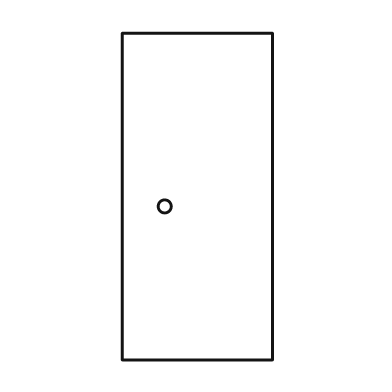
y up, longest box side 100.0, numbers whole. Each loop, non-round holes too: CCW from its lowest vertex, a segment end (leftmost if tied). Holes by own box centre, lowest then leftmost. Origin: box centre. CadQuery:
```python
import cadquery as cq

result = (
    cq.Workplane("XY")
    .moveTo(-23.0, -50.0)
    .lineTo(23.0, -50.0)
    .lineTo(23.0, 50.0)
    .lineTo(-23.0, 50.0)
    .close()
    .moveTo(-10.0, -3.0)
    .circle(2.0)
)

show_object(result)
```